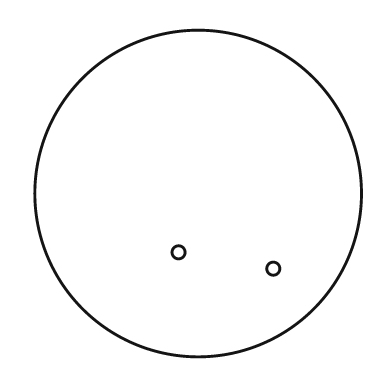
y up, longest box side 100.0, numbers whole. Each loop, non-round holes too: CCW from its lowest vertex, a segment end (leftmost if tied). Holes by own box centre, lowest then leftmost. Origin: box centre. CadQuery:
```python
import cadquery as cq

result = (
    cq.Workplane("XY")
    .moveTo(0.0, 0.0)
    .circle(50.0)
    .moveTo(23.0, -23.0)
    .circle(2.0)
    .moveTo(-6.0, -18.0)
    .circle(2.0)
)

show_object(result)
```